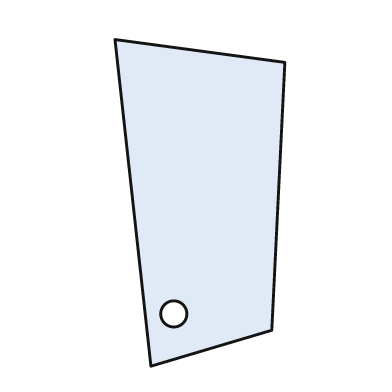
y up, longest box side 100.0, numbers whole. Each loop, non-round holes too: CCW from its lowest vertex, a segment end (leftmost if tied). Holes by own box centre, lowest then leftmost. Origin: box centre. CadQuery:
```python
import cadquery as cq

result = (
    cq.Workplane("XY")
    .moveTo(-15.0, -50.0)
    .lineTo(22.0, -39.0)
    .lineTo(26.0, 43.0)
    .lineTo(-26.0, 50.0)
    .close()
    .moveTo(-8.0, -34.0)
    .circle(4.0)
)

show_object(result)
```